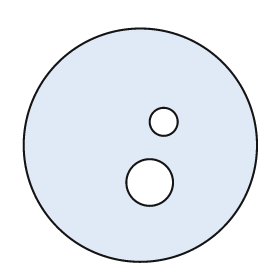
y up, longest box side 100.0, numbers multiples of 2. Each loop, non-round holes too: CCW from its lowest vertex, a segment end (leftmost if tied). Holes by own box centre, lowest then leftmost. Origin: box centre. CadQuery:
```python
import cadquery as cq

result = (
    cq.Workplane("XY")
    .moveTo(0.0, 0.0)
    .circle(50.0)
    .moveTo(4.0, -16.0)
    .circle(10.0)
    .moveTo(10.0, 10.0)
    .circle(6.0)
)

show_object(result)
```